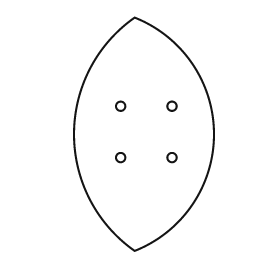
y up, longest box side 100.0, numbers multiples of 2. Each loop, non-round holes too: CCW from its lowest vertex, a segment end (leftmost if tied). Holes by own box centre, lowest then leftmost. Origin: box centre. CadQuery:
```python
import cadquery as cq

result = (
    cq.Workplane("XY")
    .moveTo(-4.0, -50.0)
    .threePointArc((30.0, 0.0), (-4.0, 50.0))
    .threePointArc((-30.0, 0.0), (-4.0, -50.0))
    .close()
    .moveTo(-10.0, -10.0)
    .circle(2.0)
    .moveTo(12.0, -10.0)
    .circle(2.0)
    .moveTo(-10.0, 12.0)
    .circle(2.0)
    .moveTo(12.0, 12.0)
    .circle(2.0)
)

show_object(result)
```